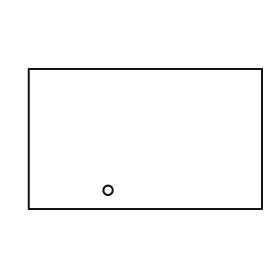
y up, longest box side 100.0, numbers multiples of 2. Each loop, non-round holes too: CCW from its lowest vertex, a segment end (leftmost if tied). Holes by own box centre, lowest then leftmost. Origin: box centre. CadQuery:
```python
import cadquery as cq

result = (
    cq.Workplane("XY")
    .moveTo(-50.0, -30.0)
    .lineTo(50.0, -30.0)
    .lineTo(50.0, 30.0)
    .lineTo(-50.0, 30.0)
    .close()
    .moveTo(-16.0, -22.0)
    .circle(2.0)
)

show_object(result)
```